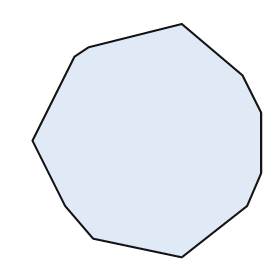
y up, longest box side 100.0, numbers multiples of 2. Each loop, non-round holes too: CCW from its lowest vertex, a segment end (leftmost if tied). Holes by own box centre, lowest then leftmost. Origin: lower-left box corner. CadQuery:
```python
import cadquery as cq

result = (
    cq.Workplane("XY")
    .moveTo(64.0, 0.0)
    .lineTo(92.0, 22.0)
    .lineTo(98.0, 36.0)
    .lineTo(98.0, 62.0)
    .lineTo(90.0, 78.0)
    .lineTo(64.0, 100.0)
    .lineTo(24.0, 90.0)
    .lineTo(18.0, 86.0)
    .lineTo(0.0, 50.0)
    .lineTo(14.0, 22.0)
    .lineTo(26.0, 8.0)
    .close()
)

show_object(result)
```